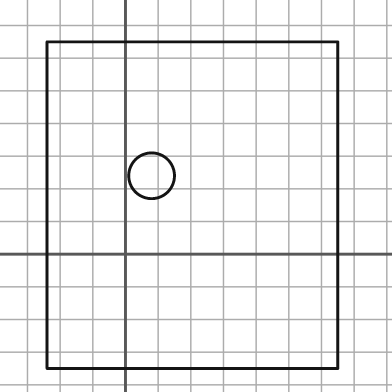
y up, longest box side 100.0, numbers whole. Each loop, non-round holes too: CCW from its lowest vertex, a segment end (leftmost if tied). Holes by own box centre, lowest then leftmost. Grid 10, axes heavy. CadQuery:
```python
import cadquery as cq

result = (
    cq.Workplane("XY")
    .moveTo(-24.0, -35.0)
    .lineTo(65.0, -35.0)
    .lineTo(65.0, 65.0)
    .lineTo(-24.0, 65.0)
    .close()
    .moveTo(8.0, 24.0)
    .circle(7.0)
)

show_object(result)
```